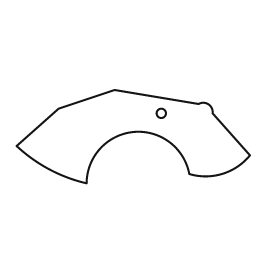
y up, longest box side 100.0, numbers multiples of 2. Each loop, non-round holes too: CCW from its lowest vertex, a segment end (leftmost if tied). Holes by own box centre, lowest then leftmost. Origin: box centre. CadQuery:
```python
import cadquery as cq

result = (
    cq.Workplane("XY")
    .moveTo(-20.0, -20.0)
    .threePointArc((0.0, 2.0), (24.0, -16.0))
    .threePointArc((38.0, -16.0), (50.0, -8.0))
    .lineTo(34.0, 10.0)
    .threePointArc((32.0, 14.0), (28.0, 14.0))
    .lineTo(-8.0, 20.0)
    .lineTo(-32.0, 12.0)
    .lineTo(-50.0, -4.0)
    .threePointArc((-36.0, -14.0), (-20.0, -20.0))
    .close()
    .moveTo(12.0, 10.0)
    .circle(2.0)
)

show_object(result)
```